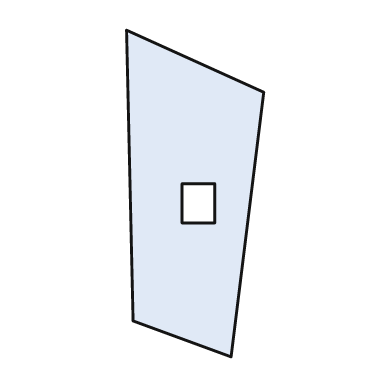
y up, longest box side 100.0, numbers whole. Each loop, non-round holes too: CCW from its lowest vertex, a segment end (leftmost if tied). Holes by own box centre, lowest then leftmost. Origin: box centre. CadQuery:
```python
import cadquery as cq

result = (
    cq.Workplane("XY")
    .moveTo(11.0, -50.0)
    .lineTo(21.0, 31.0)
    .lineTo(-21.0, 50.0)
    .lineTo(-19.0, -39.0)
    .close()
    .moveTo(-4.0, -9.0)
    .lineTo(6.0, -9.0)
    .lineTo(6.0, 3.0)
    .lineTo(-4.0, 3.0)
    .close()
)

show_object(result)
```